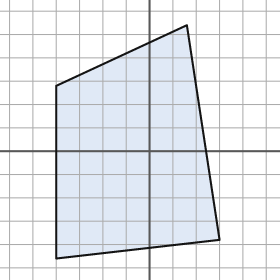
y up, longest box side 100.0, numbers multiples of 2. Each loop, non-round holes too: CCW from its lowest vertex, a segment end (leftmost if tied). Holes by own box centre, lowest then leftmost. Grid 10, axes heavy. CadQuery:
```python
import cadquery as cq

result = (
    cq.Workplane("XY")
    .moveTo(-40.0, -46.0)
    .lineTo(30.0, -38.0)
    .lineTo(16.0, 54.0)
    .lineTo(-40.0, 28.0)
    .close()
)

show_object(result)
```